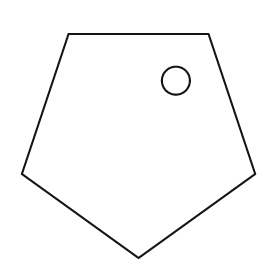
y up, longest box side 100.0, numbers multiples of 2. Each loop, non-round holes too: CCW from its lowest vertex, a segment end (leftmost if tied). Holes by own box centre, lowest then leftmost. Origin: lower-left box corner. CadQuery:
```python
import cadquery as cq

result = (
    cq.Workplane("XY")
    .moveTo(50.0, 0.0)
    .lineTo(100.0, 36.0)
    .lineTo(80.0, 96.0)
    .lineTo(20.0, 96.0)
    .lineTo(0.0, 36.0)
    .close()
    .moveTo(66.0, 76.0)
    .circle(6.0)
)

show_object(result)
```